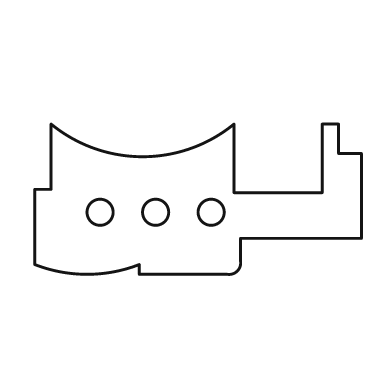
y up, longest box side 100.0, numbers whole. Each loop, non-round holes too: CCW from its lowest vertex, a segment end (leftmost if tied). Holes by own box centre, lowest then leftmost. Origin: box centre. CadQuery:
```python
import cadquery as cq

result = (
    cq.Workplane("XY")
    .moveTo(-18.0, -23.0)
    .lineTo(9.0, -23.0)
    .threePointArc((12.0, -22.0), (13.0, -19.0))
    .lineTo(13.0, -12.0)
    .lineTo(50.0, -12.0)
    .lineTo(50.0, 14.0)
    .lineTo(43.0, 14.0)
    .lineTo(43.0, 23.0)
    .lineTo(38.0, 23.0)
    .lineTo(38.0, 2.0)
    .lineTo(11.0, 2.0)
    .lineTo(11.0, 23.0)
    .threePointArc((-17.0, 13.0), (-45.0, 23.0))
    .lineTo(-45.0, 3.0)
    .lineTo(-50.0, 3.0)
    .lineTo(-50.0, -20.0)
    .threePointArc((-34.0, -23.0), (-18.0, -20.0))
    .close()
    .moveTo(-30.0, -4.0)
    .circle(4.0)
    .moveTo(-13.0, -4.0)
    .circle(4.0)
    .moveTo(4.0, -4.0)
    .circle(4.0)
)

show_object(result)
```